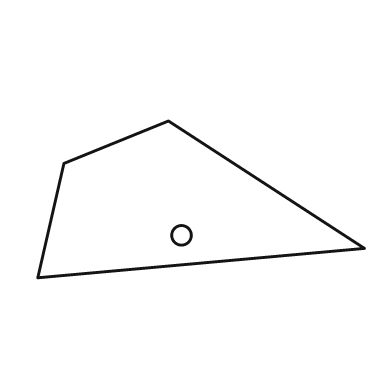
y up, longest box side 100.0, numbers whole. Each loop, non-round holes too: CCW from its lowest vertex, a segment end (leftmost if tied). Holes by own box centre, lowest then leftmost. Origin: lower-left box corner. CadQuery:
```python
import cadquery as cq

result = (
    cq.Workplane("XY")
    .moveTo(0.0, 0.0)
    .lineTo(100.0, 9.0)
    .lineTo(40.0, 48.0)
    .lineTo(8.0, 35.0)
    .close()
    .moveTo(44.0, 13.0)
    .circle(3.0)
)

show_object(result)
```